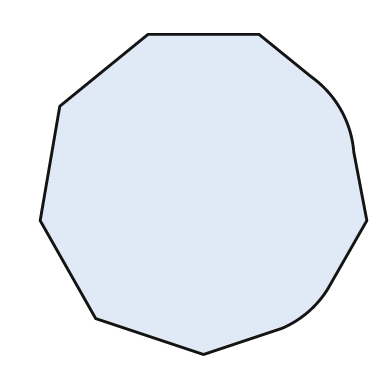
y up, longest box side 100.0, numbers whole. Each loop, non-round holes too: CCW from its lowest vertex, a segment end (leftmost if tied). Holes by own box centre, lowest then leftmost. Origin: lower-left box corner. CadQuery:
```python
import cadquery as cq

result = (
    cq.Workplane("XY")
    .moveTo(50.0, 0.0)
    .lineTo(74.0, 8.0)
    .threePointArc((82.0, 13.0), (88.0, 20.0))
    .lineTo(100.0, 41.0)
    .lineTo(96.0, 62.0)
    .threePointArc((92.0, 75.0), (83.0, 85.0))
    .lineTo(67.0, 98.0)
    .lineTo(33.0, 98.0)
    .lineTo(6.0, 76.0)
    .lineTo(0.0, 41.0)
    .lineTo(17.0, 11.0)
    .close()
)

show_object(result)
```